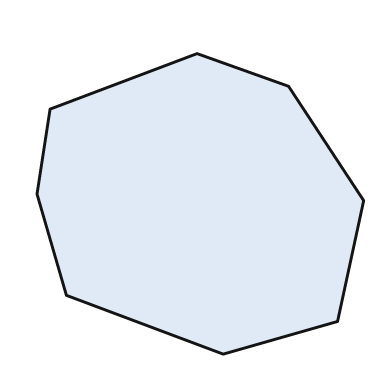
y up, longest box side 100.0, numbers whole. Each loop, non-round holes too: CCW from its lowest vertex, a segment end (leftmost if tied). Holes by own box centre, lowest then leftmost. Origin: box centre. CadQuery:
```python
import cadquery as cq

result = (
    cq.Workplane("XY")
    .moveTo(7.0, -46.0)
    .lineTo(42.0, -36.0)
    .lineTo(50.0, 1.0)
    .lineTo(27.0, 36.0)
    .lineTo(-1.0, 46.0)
    .lineTo(-46.0, 29.0)
    .lineTo(-50.0, 3.0)
    .lineTo(-41.0, -28.0)
    .close()
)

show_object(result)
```